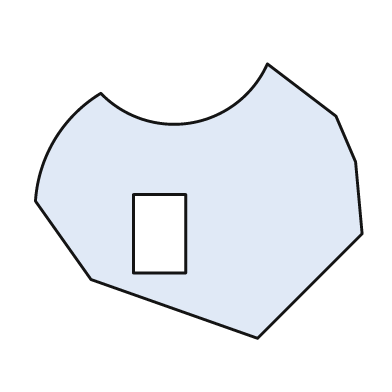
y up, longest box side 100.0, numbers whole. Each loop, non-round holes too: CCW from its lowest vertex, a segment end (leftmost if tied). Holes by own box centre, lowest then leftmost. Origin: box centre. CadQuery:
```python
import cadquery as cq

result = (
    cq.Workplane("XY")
    .moveTo(18.0, -42.0)
    .lineTo(50.0, -10.0)
    .lineTo(48.0, 12.0)
    .lineTo(42.0, 26.0)
    .lineTo(21.0, 42.0)
    .threePointArc((-2.0, 24.0), (-30.0, 33.0))
    .threePointArc((-44.0, 19.0), (-50.0, 0.0))
    .lineTo(-33.0, -24.0)
    .close()
    .moveTo(-20.0, -22.0)
    .lineTo(-4.0, -22.0)
    .lineTo(-4.0, 2.0)
    .lineTo(-20.0, 2.0)
    .close()
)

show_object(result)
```